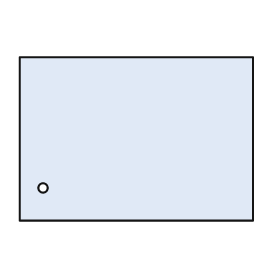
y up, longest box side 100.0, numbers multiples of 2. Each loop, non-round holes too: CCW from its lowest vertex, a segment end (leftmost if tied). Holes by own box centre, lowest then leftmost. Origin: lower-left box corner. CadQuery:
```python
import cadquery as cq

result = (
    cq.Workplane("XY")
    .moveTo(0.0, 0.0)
    .lineTo(100.0, 0.0)
    .lineTo(100.0, 70.0)
    .lineTo(0.0, 70.0)
    .close()
    .moveTo(10.0, 14.0)
    .circle(2.0)
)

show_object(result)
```